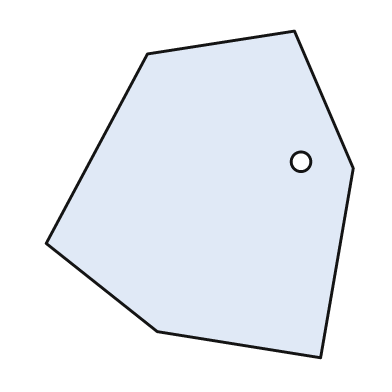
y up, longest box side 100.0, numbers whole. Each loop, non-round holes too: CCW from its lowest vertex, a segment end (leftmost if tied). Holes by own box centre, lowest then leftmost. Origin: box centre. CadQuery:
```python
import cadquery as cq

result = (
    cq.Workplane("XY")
    .moveTo(37.0, -50.0)
    .lineTo(47.0, 8.0)
    .lineTo(29.0, 50.0)
    .lineTo(-16.0, 43.0)
    .lineTo(-47.0, -15.0)
    .lineTo(-13.0, -42.0)
    .close()
    .moveTo(31.0, 10.0)
    .circle(3.0)
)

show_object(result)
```